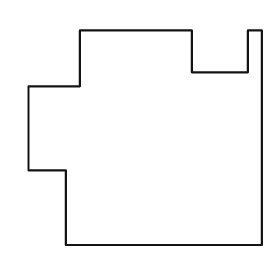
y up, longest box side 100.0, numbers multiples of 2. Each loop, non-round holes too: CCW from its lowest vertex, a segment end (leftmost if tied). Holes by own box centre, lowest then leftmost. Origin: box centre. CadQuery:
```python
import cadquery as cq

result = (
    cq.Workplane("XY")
    .moveTo(-34.0, -46.0)
    .lineTo(50.0, -46.0)
    .lineTo(50.0, 46.0)
    .lineTo(44.0, 46.0)
    .lineTo(44.0, 28.0)
    .lineTo(20.0, 28.0)
    .lineTo(20.0, 46.0)
    .lineTo(-28.0, 46.0)
    .lineTo(-28.0, 22.0)
    .lineTo(-50.0, 22.0)
    .lineTo(-50.0, -14.0)
    .lineTo(-34.0, -14.0)
    .close()
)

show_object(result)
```